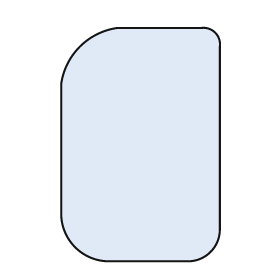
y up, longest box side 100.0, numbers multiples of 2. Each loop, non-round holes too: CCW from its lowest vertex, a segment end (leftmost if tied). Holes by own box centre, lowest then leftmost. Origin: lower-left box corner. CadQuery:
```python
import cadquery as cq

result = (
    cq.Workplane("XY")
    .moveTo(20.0, 0.0)
    .lineTo(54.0, 0.0)
    .threePointArc((64.0, 4.0), (68.0, 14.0))
    .lineTo(68.0, 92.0)
    .threePointArc((66.0, 98.0), (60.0, 100.0))
    .lineTo(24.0, 100.0)
    .threePointArc((8.0, 92.0), (0.0, 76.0))
    .lineTo(0.0, 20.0)
    .threePointArc((6.0, 6.0), (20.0, 0.0))
    .close()
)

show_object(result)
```